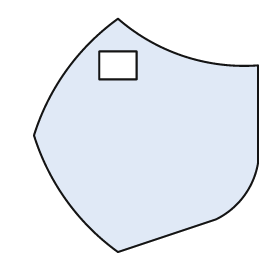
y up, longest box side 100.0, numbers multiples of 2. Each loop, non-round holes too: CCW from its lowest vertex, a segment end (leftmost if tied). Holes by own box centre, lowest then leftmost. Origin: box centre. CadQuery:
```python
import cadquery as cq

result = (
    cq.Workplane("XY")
    .moveTo(-12.0, -50.0)
    .lineTo(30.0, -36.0)
    .threePointArc((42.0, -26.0), (48.0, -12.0))
    .lineTo(48.0, 30.0)
    .threePointArc((16.0, 34.0), (-12.0, 50.0))
    .threePointArc((-34.0, 28.0), (-48.0, 0.0))
    .threePointArc((-34.0, -28.0), (-12.0, -50.0))
    .close()
    .moveTo(-20.0, 24.0)
    .lineTo(-4.0, 24.0)
    .lineTo(-4.0, 36.0)
    .lineTo(-20.0, 36.0)
    .close()
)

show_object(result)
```